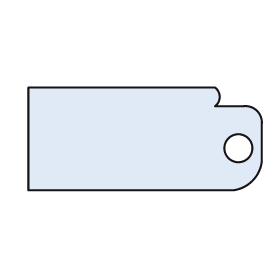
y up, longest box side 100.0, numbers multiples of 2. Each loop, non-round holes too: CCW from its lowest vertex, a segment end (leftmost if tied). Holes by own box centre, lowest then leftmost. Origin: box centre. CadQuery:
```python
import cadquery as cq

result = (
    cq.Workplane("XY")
    .moveTo(-50.0, -22.0)
    .lineTo(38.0, -22.0)
    .threePointArc((46.0, -18.0), (50.0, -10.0))
    .lineTo(50.0, 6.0)
    .threePointArc((48.0, 12.0), (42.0, 14.0))
    .lineTo(30.0, 14.0)
    .threePointArc((32.0, 18.0), (30.0, 22.0))
    .lineTo(-50.0, 22.0)
    .close()
    .moveTo(40.0, -4.0)
    .circle(6.0)
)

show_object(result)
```